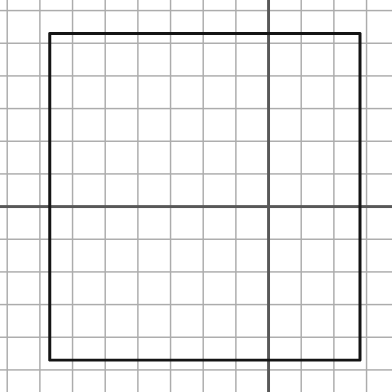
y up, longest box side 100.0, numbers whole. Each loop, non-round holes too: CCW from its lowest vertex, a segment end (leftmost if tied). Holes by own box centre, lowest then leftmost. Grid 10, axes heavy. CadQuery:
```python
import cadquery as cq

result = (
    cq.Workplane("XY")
    .moveTo(-67.0, -47.0)
    .lineTo(28.0, -47.0)
    .lineTo(28.0, 53.0)
    .lineTo(-67.0, 53.0)
    .close()
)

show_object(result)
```